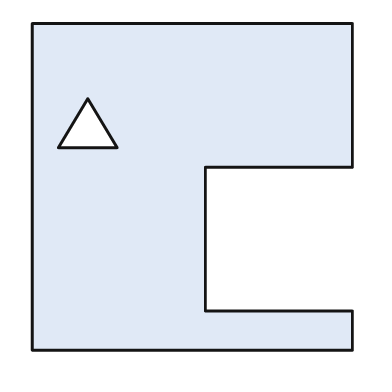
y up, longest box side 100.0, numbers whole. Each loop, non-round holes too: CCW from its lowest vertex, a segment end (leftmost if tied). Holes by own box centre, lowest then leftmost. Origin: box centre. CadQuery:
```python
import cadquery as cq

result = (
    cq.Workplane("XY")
    .moveTo(-49.0, -50.0)
    .lineTo(49.0, -50.0)
    .lineTo(49.0, -38.0)
    .lineTo(4.0, -38.0)
    .lineTo(4.0, 6.0)
    .lineTo(49.0, 6.0)
    .lineTo(49.0, 50.0)
    .lineTo(-49.0, 50.0)
    .close()
    .moveTo(-41.0, 12.0)
    .lineTo(-23.0, 12.0)
    .lineTo(-32.0, 27.0)
    .close()
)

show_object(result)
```